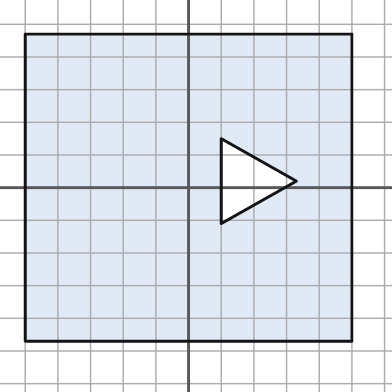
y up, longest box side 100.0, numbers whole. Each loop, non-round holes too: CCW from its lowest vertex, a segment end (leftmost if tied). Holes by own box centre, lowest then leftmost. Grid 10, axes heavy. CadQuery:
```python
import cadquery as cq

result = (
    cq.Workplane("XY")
    .moveTo(-50.0, -47.0)
    .lineTo(50.0, -47.0)
    .lineTo(50.0, 47.0)
    .lineTo(-50.0, 47.0)
    .close()
    .moveTo(10.0, -11.0)
    .lineTo(33.0, 2.0)
    .lineTo(10.0, 15.0)
    .close()
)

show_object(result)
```